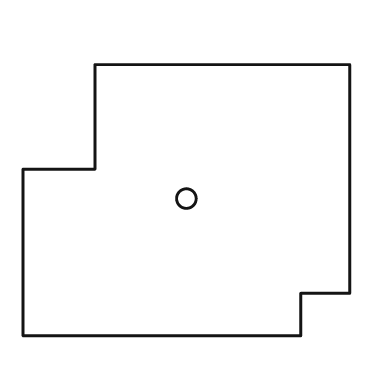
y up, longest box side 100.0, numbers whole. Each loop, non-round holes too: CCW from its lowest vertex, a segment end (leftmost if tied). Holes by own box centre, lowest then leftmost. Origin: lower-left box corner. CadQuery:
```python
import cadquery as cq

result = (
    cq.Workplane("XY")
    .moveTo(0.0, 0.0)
    .lineTo(85.0, 0.0)
    .lineTo(85.0, 13.0)
    .lineTo(100.0, 13.0)
    .lineTo(100.0, 83.0)
    .lineTo(22.0, 83.0)
    .lineTo(22.0, 51.0)
    .lineTo(0.0, 51.0)
    .close()
    .moveTo(50.0, 42.0)
    .circle(3.0)
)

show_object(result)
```